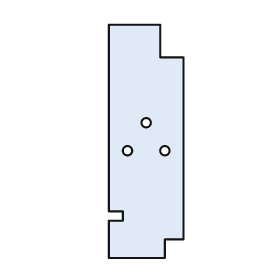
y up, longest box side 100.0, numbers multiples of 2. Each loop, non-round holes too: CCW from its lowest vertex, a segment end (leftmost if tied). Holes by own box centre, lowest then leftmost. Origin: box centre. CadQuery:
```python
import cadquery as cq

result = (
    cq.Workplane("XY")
    .moveTo(-16.0, -50.0)
    .lineTo(8.0, -50.0)
    .lineTo(8.0, -42.0)
    .lineTo(16.0, -42.0)
    .lineTo(16.0, 36.0)
    .lineTo(6.0, 36.0)
    .lineTo(6.0, 50.0)
    .lineTo(-16.0, 50.0)
    .lineTo(-16.0, -30.0)
    .lineTo(-10.0, -30.0)
    .lineTo(-10.0, -34.0)
    .lineTo(-16.0, -34.0)
    .close()
    .moveTo(-8.0, -4.0)
    .circle(2.0)
    .moveTo(8.0, -4.0)
    .circle(2.0)
    .moveTo(0.0, 8.0)
    .circle(2.0)
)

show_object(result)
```